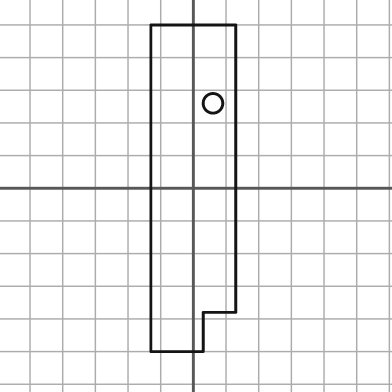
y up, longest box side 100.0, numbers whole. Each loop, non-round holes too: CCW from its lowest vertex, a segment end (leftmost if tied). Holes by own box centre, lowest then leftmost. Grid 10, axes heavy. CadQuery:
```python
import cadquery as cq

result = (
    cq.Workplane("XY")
    .moveTo(-13.0, -50.0)
    .lineTo(3.0, -50.0)
    .lineTo(3.0, -38.0)
    .lineTo(13.0, -38.0)
    .lineTo(13.0, 50.0)
    .lineTo(-13.0, 50.0)
    .close()
    .moveTo(6.0, 26.0)
    .circle(3.0)
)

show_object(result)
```